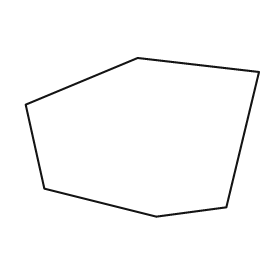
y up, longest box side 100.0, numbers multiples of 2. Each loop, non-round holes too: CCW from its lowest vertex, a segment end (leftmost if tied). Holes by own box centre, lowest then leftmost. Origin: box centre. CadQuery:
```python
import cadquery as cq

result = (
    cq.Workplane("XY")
    .moveTo(6.0, -34.0)
    .lineTo(36.0, -30.0)
    .lineTo(50.0, 28.0)
    .lineTo(-2.0, 34.0)
    .lineTo(-50.0, 14.0)
    .lineTo(-42.0, -22.0)
    .close()
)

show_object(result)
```